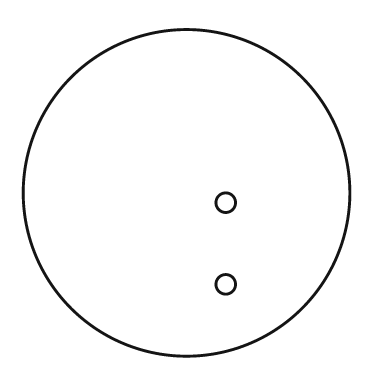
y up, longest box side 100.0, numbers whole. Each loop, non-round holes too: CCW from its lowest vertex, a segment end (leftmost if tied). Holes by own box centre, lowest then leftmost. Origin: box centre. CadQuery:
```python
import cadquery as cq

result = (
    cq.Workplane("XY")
    .moveTo(0.0, 0.0)
    .circle(50.0)
    .moveTo(12.0, -28.0)
    .circle(3.0)
    .moveTo(12.0, -3.0)
    .circle(3.0)
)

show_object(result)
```